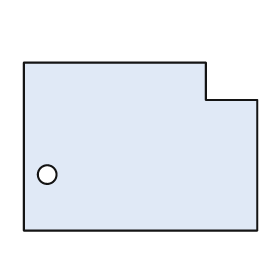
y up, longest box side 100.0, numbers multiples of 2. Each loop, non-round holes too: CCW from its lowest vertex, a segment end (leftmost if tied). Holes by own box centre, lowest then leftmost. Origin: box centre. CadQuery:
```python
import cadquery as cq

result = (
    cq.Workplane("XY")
    .moveTo(-50.0, -36.0)
    .lineTo(50.0, -36.0)
    .lineTo(50.0, 20.0)
    .lineTo(28.0, 20.0)
    .lineTo(28.0, 36.0)
    .lineTo(-50.0, 36.0)
    .close()
    .moveTo(-40.0, -12.0)
    .circle(4.0)
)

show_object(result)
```